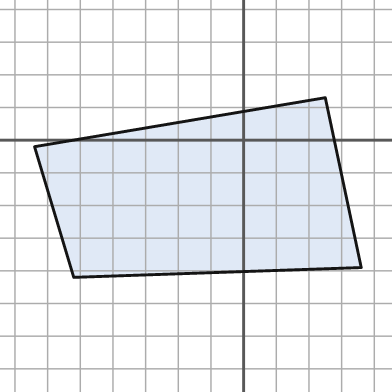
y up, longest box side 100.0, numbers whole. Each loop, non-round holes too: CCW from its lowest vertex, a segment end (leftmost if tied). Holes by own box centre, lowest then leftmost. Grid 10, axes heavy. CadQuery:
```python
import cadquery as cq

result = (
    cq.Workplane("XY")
    .moveTo(-52.0, -42.0)
    .lineTo(36.0, -39.0)
    .lineTo(25.0, 13.0)
    .lineTo(-64.0, -2.0)
    .close()
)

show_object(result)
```